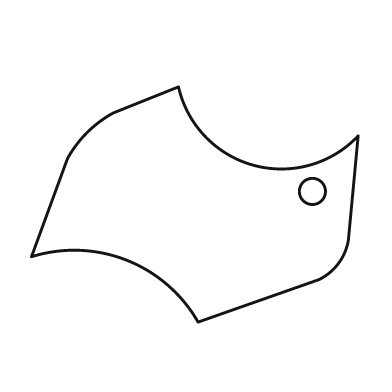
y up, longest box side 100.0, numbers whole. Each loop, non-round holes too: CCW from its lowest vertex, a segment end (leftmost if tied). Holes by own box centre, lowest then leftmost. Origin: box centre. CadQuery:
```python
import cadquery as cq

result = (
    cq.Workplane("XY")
    .moveTo(1.0, -36.0)
    .lineTo(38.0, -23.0)
    .threePointArc((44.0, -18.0), (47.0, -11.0))
    .lineTo(50.0, 21.0)
    .threePointArc((18.0, 12.0), (-5.0, 36.0))
    .lineTo(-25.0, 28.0)
    .threePointArc((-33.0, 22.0), (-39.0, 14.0))
    .lineTo(-50.0, -16.0)
    .threePointArc((-21.0, -17.0), (1.0, -36.0))
    .close()
    .moveTo(36.0, 4.0)
    .circle(4.0)
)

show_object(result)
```